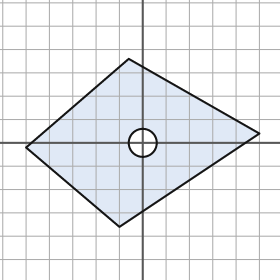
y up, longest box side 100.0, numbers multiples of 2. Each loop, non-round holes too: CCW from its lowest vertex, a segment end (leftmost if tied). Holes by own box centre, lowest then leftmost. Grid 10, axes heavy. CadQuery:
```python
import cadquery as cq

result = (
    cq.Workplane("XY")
    .moveTo(-10.0, -36.0)
    .lineTo(50.0, 4.0)
    .lineTo(-6.0, 36.0)
    .lineTo(-50.0, -2.0)
    .close()
    .moveTo(0.0, 0.0)
    .circle(6.0)
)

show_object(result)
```